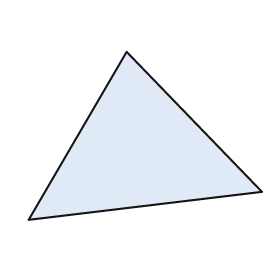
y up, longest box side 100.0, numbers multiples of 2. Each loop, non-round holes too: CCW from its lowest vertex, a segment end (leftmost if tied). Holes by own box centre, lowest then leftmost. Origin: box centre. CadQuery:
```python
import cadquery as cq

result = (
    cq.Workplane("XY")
    .moveTo(-50.0, -36.0)
    .lineTo(50.0, -24.0)
    .lineTo(-8.0, 36.0)
    .close()
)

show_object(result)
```